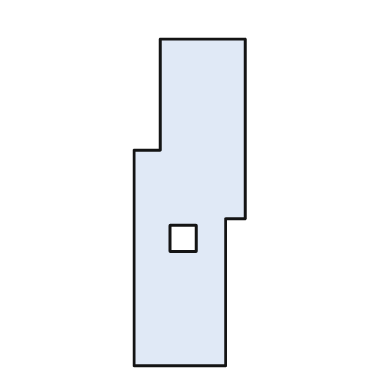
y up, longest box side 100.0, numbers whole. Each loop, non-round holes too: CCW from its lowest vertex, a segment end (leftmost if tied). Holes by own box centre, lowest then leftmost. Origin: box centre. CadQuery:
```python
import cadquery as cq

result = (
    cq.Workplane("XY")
    .moveTo(-17.0, -50.0)
    .lineTo(11.0, -50.0)
    .lineTo(11.0, -5.0)
    .lineTo(17.0, -5.0)
    .lineTo(17.0, 50.0)
    .lineTo(-9.0, 50.0)
    .lineTo(-9.0, 16.0)
    .lineTo(-17.0, 16.0)
    .close()
    .moveTo(-6.0, -15.0)
    .lineTo(2.0, -15.0)
    .lineTo(2.0, -7.0)
    .lineTo(-6.0, -7.0)
    .close()
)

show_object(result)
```